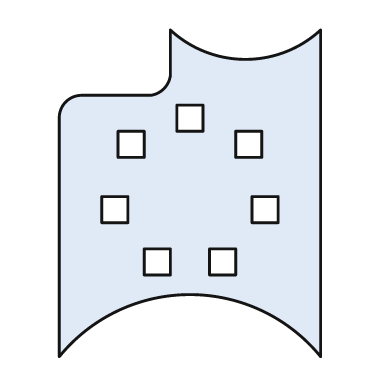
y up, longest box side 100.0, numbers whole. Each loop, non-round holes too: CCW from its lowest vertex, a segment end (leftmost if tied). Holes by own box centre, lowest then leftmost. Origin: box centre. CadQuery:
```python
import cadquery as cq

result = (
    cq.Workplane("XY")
    .moveTo(-40.0, -50.0)
    .threePointArc((0.0, -31.0), (40.0, -50.0))
    .lineTo(40.0, 50.0)
    .threePointArc((17.0, 41.0), (-6.0, 50.0))
    .lineTo(-6.0, 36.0)
    .threePointArc((-8.0, 32.0), (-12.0, 30.0))
    .lineTo(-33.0, 30.0)
    .threePointArc((-38.0, 28.0), (-40.0, 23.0))
    .close()
    .moveTo(-14.0, -25.0)
    .lineTo(-6.0, -25.0)
    .lineTo(-6.0, -17.0)
    .lineTo(-14.0, -17.0)
    .close()
    .moveTo(6.0, -25.0)
    .lineTo(14.0, -25.0)
    .lineTo(14.0, -17.0)
    .lineTo(6.0, -17.0)
    .close()
    .moveTo(-27.0, -9.0)
    .lineTo(-19.0, -9.0)
    .lineTo(-19.0, -1.0)
    .lineTo(-27.0, -1.0)
    .close()
    .moveTo(19.0, -9.0)
    .lineTo(27.0, -9.0)
    .lineTo(27.0, -1.0)
    .lineTo(19.0, -1.0)
    .close()
    .moveTo(-22.0, 11.0)
    .lineTo(-14.0, 11.0)
    .lineTo(-14.0, 19.0)
    .lineTo(-22.0, 19.0)
    .close()
    .moveTo(14.0, 11.0)
    .lineTo(22.0, 11.0)
    .lineTo(22.0, 19.0)
    .lineTo(14.0, 19.0)
    .close()
    .moveTo(-4.0, 19.0)
    .lineTo(4.0, 19.0)
    .lineTo(4.0, 27.0)
    .lineTo(-4.0, 27.0)
    .close()
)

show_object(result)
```